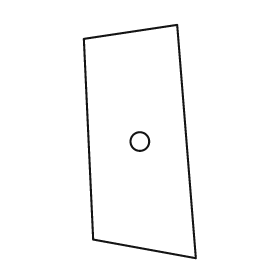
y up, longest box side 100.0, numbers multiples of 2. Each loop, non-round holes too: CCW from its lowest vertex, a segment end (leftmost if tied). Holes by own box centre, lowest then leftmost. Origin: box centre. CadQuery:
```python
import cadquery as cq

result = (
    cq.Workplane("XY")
    .moveTo(24.0, -50.0)
    .lineTo(16.0, 50.0)
    .lineTo(-24.0, 44.0)
    .lineTo(-20.0, -42.0)
    .close()
    .moveTo(0.0, 0.0)
    .circle(4.0)
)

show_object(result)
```